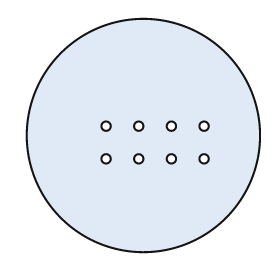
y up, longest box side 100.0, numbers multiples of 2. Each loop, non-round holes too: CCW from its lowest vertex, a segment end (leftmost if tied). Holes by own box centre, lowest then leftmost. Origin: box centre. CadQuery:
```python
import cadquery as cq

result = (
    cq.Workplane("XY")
    .moveTo(0.0, 0.0)
    .circle(50.0)
    .moveTo(-16.0, -10.0)
    .circle(2.0)
    .moveTo(-2.0, -10.0)
    .circle(2.0)
    .moveTo(12.0, -10.0)
    .circle(2.0)
    .moveTo(26.0, -10.0)
    .circle(2.0)
    .moveTo(-16.0, 4.0)
    .circle(2.0)
    .moveTo(-2.0, 4.0)
    .circle(2.0)
    .moveTo(12.0, 4.0)
    .circle(2.0)
    .moveTo(26.0, 4.0)
    .circle(2.0)
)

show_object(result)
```